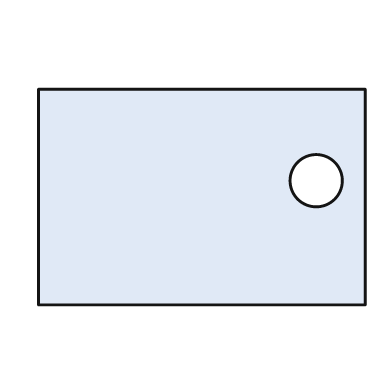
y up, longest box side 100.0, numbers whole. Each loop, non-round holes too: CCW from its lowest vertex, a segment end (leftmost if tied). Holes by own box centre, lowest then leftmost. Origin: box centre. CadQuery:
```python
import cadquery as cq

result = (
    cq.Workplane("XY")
    .moveTo(-50.0, -33.0)
    .lineTo(50.0, -33.0)
    .lineTo(50.0, 33.0)
    .lineTo(-50.0, 33.0)
    .close()
    .moveTo(35.0, 5.0)
    .circle(8.0)
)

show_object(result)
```